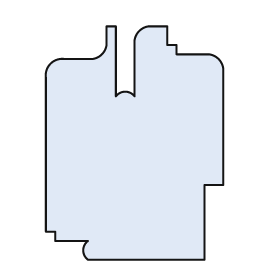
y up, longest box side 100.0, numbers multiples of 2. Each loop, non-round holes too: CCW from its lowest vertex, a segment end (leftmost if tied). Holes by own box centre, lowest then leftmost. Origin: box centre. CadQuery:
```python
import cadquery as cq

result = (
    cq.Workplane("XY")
    .moveTo(-20.0, -50.0)
    .lineTo(30.0, -50.0)
    .lineTo(30.0, -18.0)
    .lineTo(38.0, -18.0)
    .lineTo(38.0, 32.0)
    .threePointArc((36.0, 36.0), (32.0, 38.0))
    .lineTo(18.0, 38.0)
    .lineTo(18.0, 42.0)
    .lineTo(14.0, 42.0)
    .lineTo(14.0, 50.0)
    .lineTo(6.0, 50.0)
    .threePointArc((2.0, 48.0), (0.0, 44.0))
    .lineTo(0.0, 20.0)
    .threePointArc((-4.0, 22.0), (-8.0, 20.0))
    .lineTo(-8.0, 50.0)
    .lineTo(-12.0, 50.0)
    .lineTo(-12.0, 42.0)
    .threePointArc((-14.0, 38.0), (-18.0, 36.0))
    .lineTo(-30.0, 36.0)
    .threePointArc((-36.0, 34.0), (-38.0, 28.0))
    .lineTo(-38.0, -38.0)
    .lineTo(-34.0, -38.0)
    .lineTo(-34.0, -42.0)
    .lineTo(-20.0, -42.0)
    .threePointArc((-22.0, -46.0), (-20.0, -50.0))
    .close()
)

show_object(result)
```